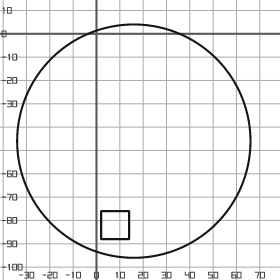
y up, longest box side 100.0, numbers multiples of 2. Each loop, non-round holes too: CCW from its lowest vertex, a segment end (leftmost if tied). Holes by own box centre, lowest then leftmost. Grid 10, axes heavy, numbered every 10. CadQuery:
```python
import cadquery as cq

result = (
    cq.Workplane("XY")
    .moveTo(16.0, -46.0)
    .circle(50.0)
    .moveTo(2.0, -88.0)
    .lineTo(14.0, -88.0)
    .lineTo(14.0, -76.0)
    .lineTo(2.0, -76.0)
    .close()
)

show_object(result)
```